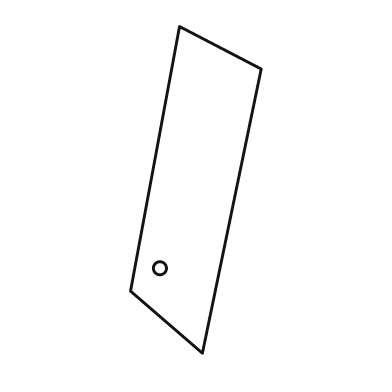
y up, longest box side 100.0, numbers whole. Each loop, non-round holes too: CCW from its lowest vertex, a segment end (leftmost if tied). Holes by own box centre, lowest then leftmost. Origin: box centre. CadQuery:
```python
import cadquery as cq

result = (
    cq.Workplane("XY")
    .moveTo(2.0, -50.0)
    .lineTo(20.0, 37.0)
    .lineTo(-5.0, 50.0)
    .lineTo(-20.0, -31.0)
    .close()
    .moveTo(-11.0, -24.0)
    .circle(2.0)
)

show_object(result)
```